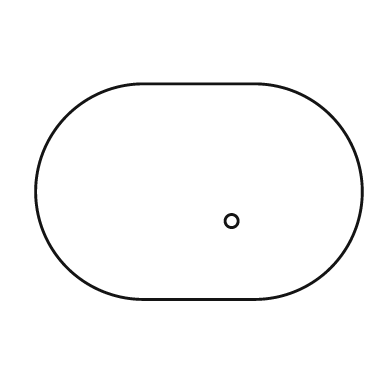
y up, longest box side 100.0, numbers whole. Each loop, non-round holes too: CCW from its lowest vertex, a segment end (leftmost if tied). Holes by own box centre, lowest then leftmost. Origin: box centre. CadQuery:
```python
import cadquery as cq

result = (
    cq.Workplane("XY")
    .moveTo(-17.0, -33.0)
    .lineTo(17.0, -33.0)
    .threePointArc((50.0, 0.0), (17.0, 33.0))
    .lineTo(-17.0, 33.0)
    .threePointArc((-50.0, 0.0), (-17.0, -33.0))
    .close()
    .moveTo(10.0, -9.0)
    .circle(2.0)
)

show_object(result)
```